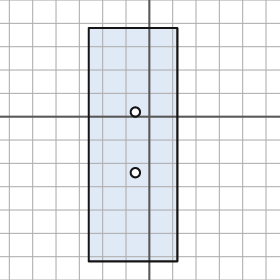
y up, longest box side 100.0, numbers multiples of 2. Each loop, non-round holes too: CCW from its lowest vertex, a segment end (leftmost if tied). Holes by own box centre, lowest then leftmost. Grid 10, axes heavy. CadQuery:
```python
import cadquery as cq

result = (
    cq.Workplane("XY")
    .moveTo(-26.0, -62.0)
    .lineTo(12.0, -62.0)
    .lineTo(12.0, 38.0)
    .lineTo(-26.0, 38.0)
    .close()
    .moveTo(-6.0, -24.0)
    .circle(2.0)
    .moveTo(-6.0, 2.0)
    .circle(2.0)
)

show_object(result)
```